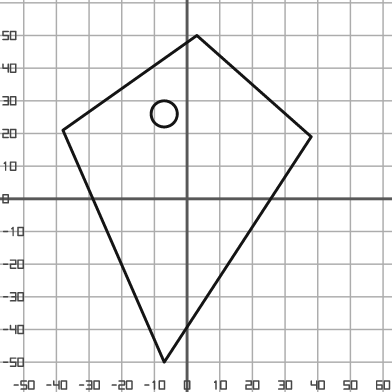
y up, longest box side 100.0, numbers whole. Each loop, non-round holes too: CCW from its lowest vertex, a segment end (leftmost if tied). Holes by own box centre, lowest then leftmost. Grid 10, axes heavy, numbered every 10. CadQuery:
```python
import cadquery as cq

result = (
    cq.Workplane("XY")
    .moveTo(-7.0, -50.0)
    .lineTo(38.0, 19.0)
    .lineTo(3.0, 50.0)
    .lineTo(-38.0, 21.0)
    .close()
    .moveTo(-7.0, 26.0)
    .circle(4.0)
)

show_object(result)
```